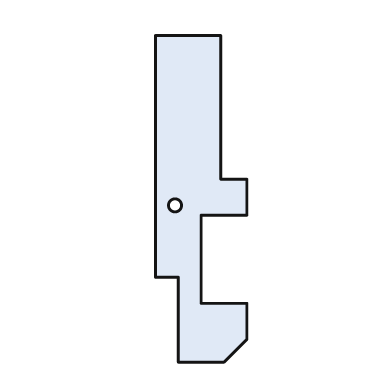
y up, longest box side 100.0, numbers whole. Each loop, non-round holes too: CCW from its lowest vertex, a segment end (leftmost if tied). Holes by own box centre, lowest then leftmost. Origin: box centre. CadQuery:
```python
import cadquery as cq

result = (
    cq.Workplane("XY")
    .moveTo(-7.0, -50.0)
    .lineTo(7.0, -50.0)
    .lineTo(14.0, -43.0)
    .lineTo(14.0, -32.0)
    .lineTo(0.0, -32.0)
    .lineTo(0.0, -5.0)
    .lineTo(14.0, -5.0)
    .lineTo(14.0, 6.0)
    .lineTo(6.0, 6.0)
    .lineTo(6.0, 50.0)
    .lineTo(-14.0, 50.0)
    .lineTo(-14.0, -24.0)
    .lineTo(-7.0, -24.0)
    .close()
    .moveTo(-8.0, -2.0)
    .circle(2.0)
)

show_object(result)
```